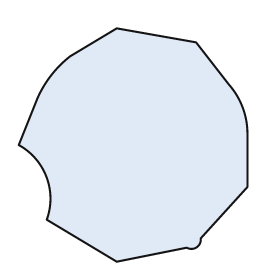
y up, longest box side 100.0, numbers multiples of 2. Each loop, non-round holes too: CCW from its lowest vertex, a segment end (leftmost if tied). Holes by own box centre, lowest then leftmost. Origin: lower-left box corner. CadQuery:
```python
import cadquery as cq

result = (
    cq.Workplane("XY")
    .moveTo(42.0, 0.0)
    .lineTo(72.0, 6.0)
    .threePointArc((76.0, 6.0), (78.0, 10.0))
    .lineTo(98.0, 32.0)
    .lineTo(98.0, 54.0)
    .threePointArc((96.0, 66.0), (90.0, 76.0))
    .lineTo(76.0, 94.0)
    .lineTo(42.0, 100.0)
    .lineTo(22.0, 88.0)
    .threePointArc((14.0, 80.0), (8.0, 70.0))
    .lineTo(0.0, 50.0)
    .threePointArc((12.0, 36.0), (12.0, 18.0))
    .close()
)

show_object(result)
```